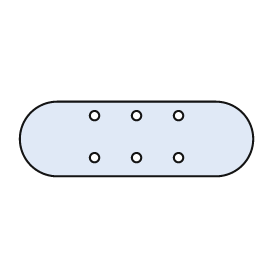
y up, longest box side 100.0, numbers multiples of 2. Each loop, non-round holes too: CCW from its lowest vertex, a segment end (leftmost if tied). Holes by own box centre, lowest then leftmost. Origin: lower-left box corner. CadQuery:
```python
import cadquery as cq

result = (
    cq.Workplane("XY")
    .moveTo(16.0, 0.0)
    .lineTo(84.0, 0.0)
    .threePointArc((100.0, 16.0), (84.0, 32.0))
    .lineTo(16.0, 32.0)
    .threePointArc((0.0, 16.0), (16.0, 0.0))
    .close()
    .moveTo(32.0, 8.0)
    .circle(2.0)
    .moveTo(50.0, 8.0)
    .circle(2.0)
    .moveTo(68.0, 8.0)
    .circle(2.0)
    .moveTo(32.0, 26.0)
    .circle(2.0)
    .moveTo(50.0, 26.0)
    .circle(2.0)
    .moveTo(68.0, 26.0)
    .circle(2.0)
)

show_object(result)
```